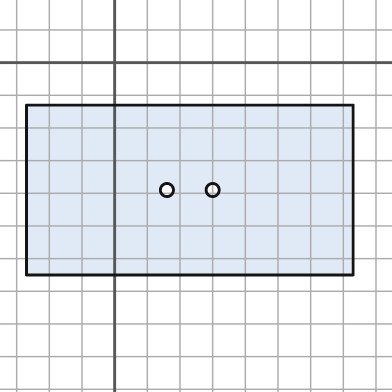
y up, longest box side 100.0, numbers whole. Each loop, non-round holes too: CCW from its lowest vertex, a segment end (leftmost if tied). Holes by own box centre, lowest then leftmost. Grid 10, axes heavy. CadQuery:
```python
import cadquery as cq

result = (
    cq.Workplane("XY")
    .moveTo(-27.0, -65.0)
    .lineTo(73.0, -65.0)
    .lineTo(73.0, -13.0)
    .lineTo(-27.0, -13.0)
    .close()
    .moveTo(16.0, -39.0)
    .circle(2.0)
    .moveTo(30.0, -39.0)
    .circle(2.0)
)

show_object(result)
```